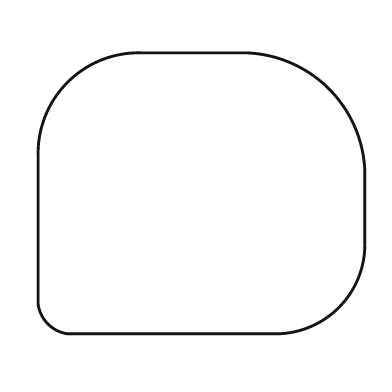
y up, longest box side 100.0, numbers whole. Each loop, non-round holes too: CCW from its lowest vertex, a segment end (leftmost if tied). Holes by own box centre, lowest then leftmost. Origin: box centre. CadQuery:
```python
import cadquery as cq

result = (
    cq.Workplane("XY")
    .moveTo(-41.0, -43.0)
    .lineTo(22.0, -43.0)
    .threePointArc((42.0, -35.0), (50.0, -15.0))
    .lineTo(50.0, 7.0)
    .threePointArc((39.0, 32.0), (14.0, 43.0))
    .lineTo(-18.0, 43.0)
    .threePointArc((-41.0, 34.0), (-50.0, 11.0))
    .lineTo(-50.0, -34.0)
    .threePointArc((-47.0, -40.0), (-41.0, -43.0))
    .close()
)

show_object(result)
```